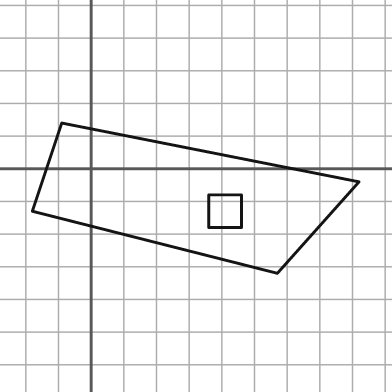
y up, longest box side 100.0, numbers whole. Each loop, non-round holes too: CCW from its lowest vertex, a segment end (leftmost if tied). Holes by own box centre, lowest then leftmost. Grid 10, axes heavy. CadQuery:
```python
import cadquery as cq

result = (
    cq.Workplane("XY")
    .moveTo(57.0, -32.0)
    .lineTo(82.0, -4.0)
    .lineTo(-9.0, 14.0)
    .lineTo(-18.0, -13.0)
    .close()
    .moveTo(36.0, -18.0)
    .lineTo(46.0, -18.0)
    .lineTo(46.0, -8.0)
    .lineTo(36.0, -8.0)
    .close()
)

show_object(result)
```